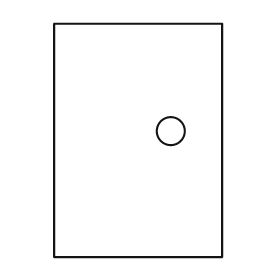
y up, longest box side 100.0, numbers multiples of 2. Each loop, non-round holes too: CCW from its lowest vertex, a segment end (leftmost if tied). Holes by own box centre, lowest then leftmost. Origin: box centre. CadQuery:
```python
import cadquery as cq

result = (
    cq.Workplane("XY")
    .moveTo(-36.0, -50.0)
    .lineTo(36.0, -50.0)
    .lineTo(36.0, 50.0)
    .lineTo(-36.0, 50.0)
    .close()
    .moveTo(14.0, 4.0)
    .circle(6.0)
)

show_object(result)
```